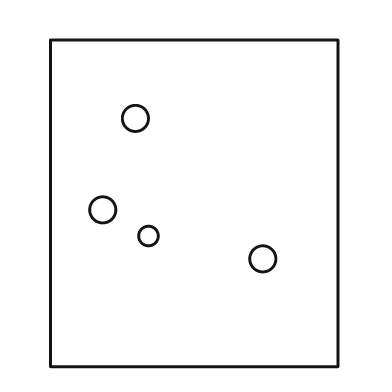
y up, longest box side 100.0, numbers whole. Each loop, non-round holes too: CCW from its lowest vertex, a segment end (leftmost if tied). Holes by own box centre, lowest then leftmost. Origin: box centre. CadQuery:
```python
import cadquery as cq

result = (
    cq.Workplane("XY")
    .moveTo(-44.0, -50.0)
    .lineTo(44.0, -50.0)
    .lineTo(44.0, 50.0)
    .lineTo(-44.0, 50.0)
    .close()
    .moveTo(21.0, -17.0)
    .circle(4.0)
    .moveTo(-14.0, -10.0)
    .circle(3.0)
    .moveTo(-28.0, -2.0)
    .circle(4.0)
    .moveTo(-18.0, 26.0)
    .circle(4.0)
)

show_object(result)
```